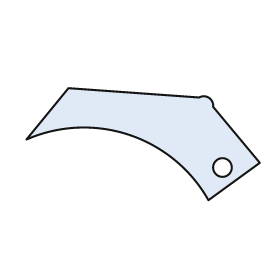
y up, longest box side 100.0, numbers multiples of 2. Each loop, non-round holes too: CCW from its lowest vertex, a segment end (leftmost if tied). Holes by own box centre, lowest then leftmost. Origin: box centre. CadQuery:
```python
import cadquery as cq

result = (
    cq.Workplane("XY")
    .moveTo(28.0, -24.0)
    .lineTo(50.0, -8.0)
    .lineTo(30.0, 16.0)
    .threePointArc((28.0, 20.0), (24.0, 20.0))
    .lineTo(-32.0, 24.0)
    .lineTo(-50.0, 2.0)
    .threePointArc((-6.0, 4.0), (28.0, -24.0))
    .close()
    .moveTo(34.0, -10.0)
    .circle(4.0)
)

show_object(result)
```